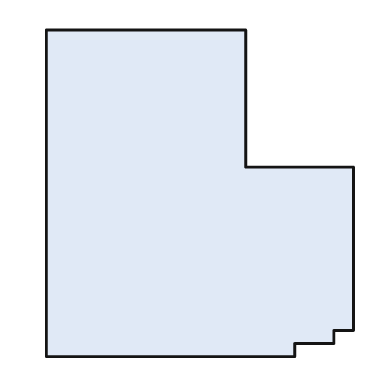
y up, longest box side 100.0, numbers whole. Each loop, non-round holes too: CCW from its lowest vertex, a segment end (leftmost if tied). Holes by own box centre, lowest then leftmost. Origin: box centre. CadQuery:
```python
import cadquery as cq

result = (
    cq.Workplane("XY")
    .moveTo(-47.0, -50.0)
    .lineTo(29.0, -50.0)
    .lineTo(29.0, -46.0)
    .lineTo(41.0, -46.0)
    .lineTo(41.0, -42.0)
    .lineTo(47.0, -42.0)
    .lineTo(47.0, 8.0)
    .lineTo(14.0, 8.0)
    .lineTo(14.0, 50.0)
    .lineTo(-47.0, 50.0)
    .close()
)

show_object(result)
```